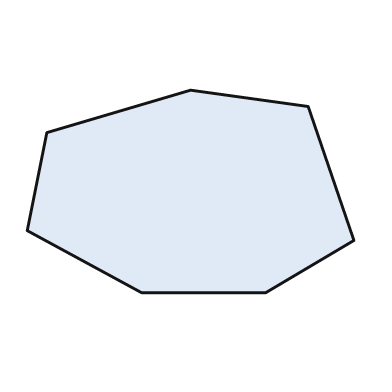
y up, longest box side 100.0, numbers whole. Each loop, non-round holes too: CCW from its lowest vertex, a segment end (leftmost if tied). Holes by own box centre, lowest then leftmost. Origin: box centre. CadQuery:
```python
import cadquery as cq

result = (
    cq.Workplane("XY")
    .moveTo(-15.0, -31.0)
    .lineTo(23.0, -31.0)
    .lineTo(50.0, -15.0)
    .lineTo(36.0, 26.0)
    .lineTo(0.0, 31.0)
    .lineTo(-44.0, 18.0)
    .lineTo(-50.0, -12.0)
    .close()
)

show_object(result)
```